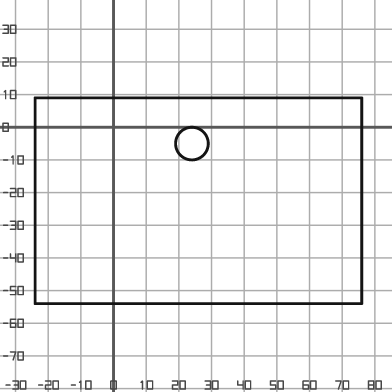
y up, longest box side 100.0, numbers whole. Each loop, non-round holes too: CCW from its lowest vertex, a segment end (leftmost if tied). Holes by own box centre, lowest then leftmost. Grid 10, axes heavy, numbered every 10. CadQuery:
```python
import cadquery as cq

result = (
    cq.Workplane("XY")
    .moveTo(-24.0, -54.0)
    .lineTo(76.0, -54.0)
    .lineTo(76.0, 9.0)
    .lineTo(-24.0, 9.0)
    .close()
    .moveTo(24.0, -5.0)
    .circle(5.0)
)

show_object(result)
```